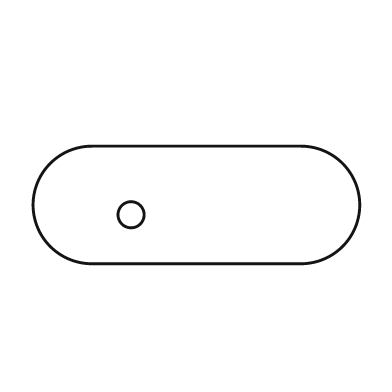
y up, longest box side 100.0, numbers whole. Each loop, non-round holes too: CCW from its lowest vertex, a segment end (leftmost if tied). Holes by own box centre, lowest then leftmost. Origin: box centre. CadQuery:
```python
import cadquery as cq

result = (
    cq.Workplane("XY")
    .moveTo(-32.0, -18.0)
    .lineTo(32.0, -18.0)
    .threePointArc((50.0, 0.0), (32.0, 18.0))
    .lineTo(-32.0, 18.0)
    .threePointArc((-50.0, 0.0), (-32.0, -18.0))
    .close()
    .moveTo(-20.0, -3.0)
    .circle(4.0)
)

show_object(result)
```